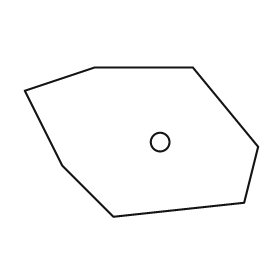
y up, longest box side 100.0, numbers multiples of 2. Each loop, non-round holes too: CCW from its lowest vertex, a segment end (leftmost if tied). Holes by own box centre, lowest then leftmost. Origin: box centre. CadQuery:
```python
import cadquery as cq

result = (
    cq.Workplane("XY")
    .moveTo(-12.0, -32.0)
    .lineTo(44.0, -26.0)
    .lineTo(50.0, -2.0)
    .lineTo(22.0, 32.0)
    .lineTo(-20.0, 32.0)
    .lineTo(-50.0, 22.0)
    .lineTo(-34.0, -10.0)
    .close()
    .moveTo(8.0, 0.0)
    .circle(4.0)
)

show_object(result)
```